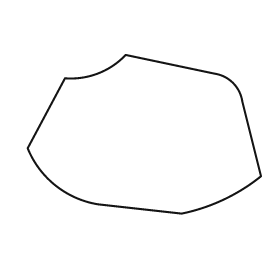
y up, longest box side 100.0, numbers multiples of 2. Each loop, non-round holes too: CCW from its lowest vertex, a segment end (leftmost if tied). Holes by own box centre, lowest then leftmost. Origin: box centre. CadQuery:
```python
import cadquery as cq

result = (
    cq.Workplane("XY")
    .moveTo(16.0, -34.0)
    .threePointArc((34.0, -28.0), (50.0, -18.0))
    .lineTo(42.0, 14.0)
    .threePointArc((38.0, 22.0), (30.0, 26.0))
    .lineTo(-8.0, 34.0)
    .threePointArc((-20.0, 26.0), (-34.0, 24.0))
    .lineTo(-50.0, -6.0)
    .threePointArc((-38.0, -22.0), (-20.0, -30.0))
    .close()
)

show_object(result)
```